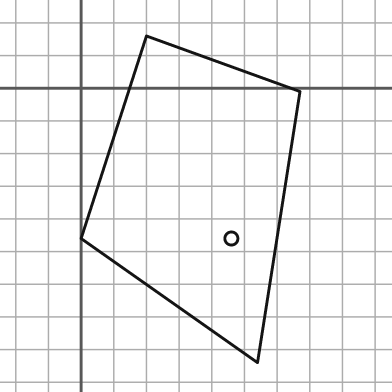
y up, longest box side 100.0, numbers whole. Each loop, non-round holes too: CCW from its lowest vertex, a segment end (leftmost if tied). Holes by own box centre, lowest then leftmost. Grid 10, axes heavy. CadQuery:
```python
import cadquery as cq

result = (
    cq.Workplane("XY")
    .moveTo(54.0, -84.0)
    .lineTo(67.0, -1.0)
    .lineTo(20.0, 16.0)
    .lineTo(0.0, -46.0)
    .close()
    .moveTo(46.0, -46.0)
    .circle(2.0)
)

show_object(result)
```